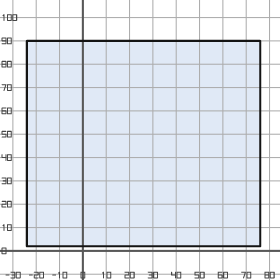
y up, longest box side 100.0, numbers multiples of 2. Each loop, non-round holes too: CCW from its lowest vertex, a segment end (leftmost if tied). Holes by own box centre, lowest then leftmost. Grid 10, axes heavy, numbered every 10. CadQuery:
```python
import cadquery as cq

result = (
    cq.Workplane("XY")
    .moveTo(-24.0, 2.0)
    .lineTo(76.0, 2.0)
    .lineTo(76.0, 90.0)
    .lineTo(-24.0, 90.0)
    .close()
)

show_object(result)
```